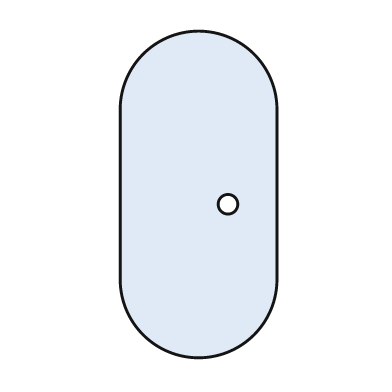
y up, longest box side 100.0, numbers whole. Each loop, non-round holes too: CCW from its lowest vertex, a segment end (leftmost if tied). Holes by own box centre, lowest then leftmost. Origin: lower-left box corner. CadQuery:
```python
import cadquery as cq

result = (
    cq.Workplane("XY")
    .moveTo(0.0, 24.0)
    .threePointArc((24.0, 0.0), (48.0, 24.0))
    .lineTo(48.0, 76.0)
    .threePointArc((24.0, 100.0), (0.0, 76.0))
    .close()
    .moveTo(33.0, 47.0)
    .circle(3.0)
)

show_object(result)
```